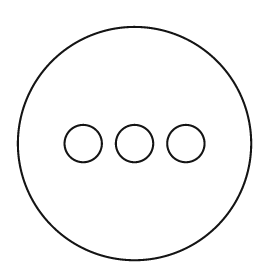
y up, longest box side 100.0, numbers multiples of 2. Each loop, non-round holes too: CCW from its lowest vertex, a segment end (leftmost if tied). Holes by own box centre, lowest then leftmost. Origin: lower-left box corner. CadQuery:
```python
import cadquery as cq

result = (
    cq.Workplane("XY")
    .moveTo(50.0, 50.0)
    .circle(50.0)
    .moveTo(28.0, 50.0)
    .circle(8.0)
    .moveTo(50.0, 50.0)
    .circle(8.0)
    .moveTo(72.0, 50.0)
    .circle(8.0)
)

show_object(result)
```